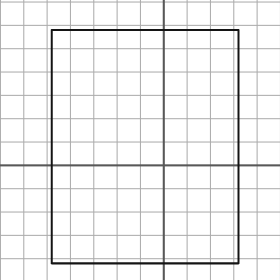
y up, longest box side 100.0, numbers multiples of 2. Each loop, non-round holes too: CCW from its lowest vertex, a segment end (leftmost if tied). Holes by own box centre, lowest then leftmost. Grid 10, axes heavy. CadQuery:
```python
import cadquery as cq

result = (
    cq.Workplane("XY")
    .moveTo(-48.0, -42.0)
    .lineTo(32.0, -42.0)
    .lineTo(32.0, 58.0)
    .lineTo(-48.0, 58.0)
    .close()
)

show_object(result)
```